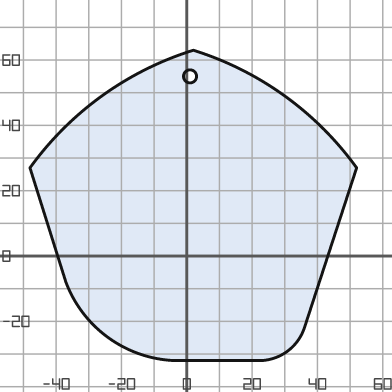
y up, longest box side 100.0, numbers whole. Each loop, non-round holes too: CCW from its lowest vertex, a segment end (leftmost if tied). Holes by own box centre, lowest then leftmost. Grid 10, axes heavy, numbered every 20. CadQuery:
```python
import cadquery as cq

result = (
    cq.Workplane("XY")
    .moveTo(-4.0, -32.0)
    .lineTo(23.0, -32.0)
    .threePointArc((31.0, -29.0), (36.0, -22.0))
    .lineTo(52.0, 27.0)
    .threePointArc((30.0, 49.0), (2.0, 63.0))
    .threePointArc((-26.0, 49.0), (-48.0, 27.0))
    .lineTo(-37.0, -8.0)
    .threePointArc((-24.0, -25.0), (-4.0, -32.0))
    .close()
    .moveTo(1.0, 55.0)
    .circle(2.0)
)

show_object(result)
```